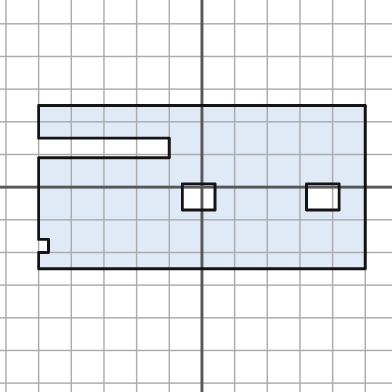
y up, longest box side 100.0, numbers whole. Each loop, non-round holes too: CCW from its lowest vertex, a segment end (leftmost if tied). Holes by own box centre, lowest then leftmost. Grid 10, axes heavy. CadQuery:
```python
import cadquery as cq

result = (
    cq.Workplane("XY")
    .moveTo(-50.0, -25.0)
    .lineTo(50.0, -25.0)
    .lineTo(50.0, 25.0)
    .lineTo(-50.0, 25.0)
    .lineTo(-50.0, 15.0)
    .lineTo(-10.0, 15.0)
    .lineTo(-10.0, 9.0)
    .lineTo(-50.0, 9.0)
    .lineTo(-50.0, -16.0)
    .lineTo(-47.0, -16.0)
    .lineTo(-47.0, -20.0)
    .lineTo(-50.0, -20.0)
    .close()
    .moveTo(-6.0, -7.0)
    .lineTo(4.0, -7.0)
    .lineTo(4.0, 1.0)
    .lineTo(-6.0, 1.0)
    .close()
    .moveTo(32.0, -7.0)
    .lineTo(42.0, -7.0)
    .lineTo(42.0, 1.0)
    .lineTo(32.0, 1.0)
    .close()
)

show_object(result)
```